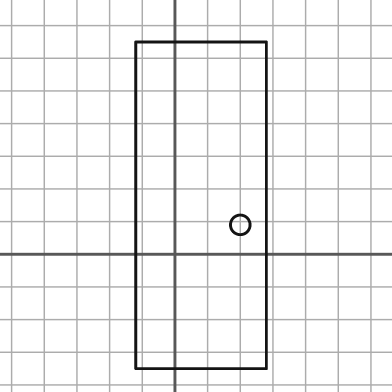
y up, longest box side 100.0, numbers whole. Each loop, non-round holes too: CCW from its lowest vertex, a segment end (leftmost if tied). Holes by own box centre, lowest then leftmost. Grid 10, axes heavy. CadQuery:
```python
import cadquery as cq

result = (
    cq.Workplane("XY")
    .moveTo(-12.0, -35.0)
    .lineTo(28.0, -35.0)
    .lineTo(28.0, 65.0)
    .lineTo(-12.0, 65.0)
    .close()
    .moveTo(20.0, 9.0)
    .circle(3.0)
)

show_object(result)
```